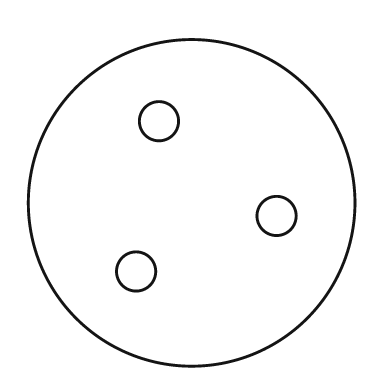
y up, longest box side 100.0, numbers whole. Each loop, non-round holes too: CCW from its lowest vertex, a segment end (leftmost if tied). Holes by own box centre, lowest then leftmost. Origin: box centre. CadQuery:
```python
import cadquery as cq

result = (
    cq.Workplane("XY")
    .moveTo(0.0, 0.0)
    .circle(50.0)
    .moveTo(-17.0, -21.0)
    .circle(6.0)
    .moveTo(26.0, -4.0)
    .circle(6.0)
    .moveTo(-10.0, 25.0)
    .circle(6.0)
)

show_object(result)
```